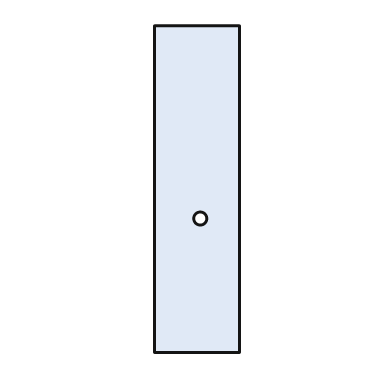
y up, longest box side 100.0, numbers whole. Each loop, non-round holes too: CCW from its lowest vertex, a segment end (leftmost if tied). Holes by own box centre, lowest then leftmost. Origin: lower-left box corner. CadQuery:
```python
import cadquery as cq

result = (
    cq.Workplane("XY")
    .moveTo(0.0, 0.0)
    .lineTo(26.0, 0.0)
    .lineTo(26.0, 100.0)
    .lineTo(0.0, 100.0)
    .close()
    .moveTo(14.0, 41.0)
    .circle(2.0)
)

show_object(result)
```